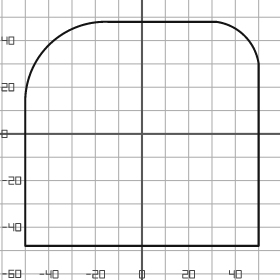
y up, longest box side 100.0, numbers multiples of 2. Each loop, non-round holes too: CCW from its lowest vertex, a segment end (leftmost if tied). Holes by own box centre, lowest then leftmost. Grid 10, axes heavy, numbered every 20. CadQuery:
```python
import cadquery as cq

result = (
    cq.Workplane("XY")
    .moveTo(-50.0, -48.0)
    .lineTo(50.0, -48.0)
    .lineTo(50.0, 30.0)
    .threePointArc((44.0, 42.0), (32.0, 48.0))
    .lineTo(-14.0, 48.0)
    .threePointArc((-40.0, 38.0), (-50.0, 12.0))
    .close()
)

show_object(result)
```